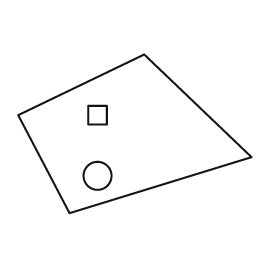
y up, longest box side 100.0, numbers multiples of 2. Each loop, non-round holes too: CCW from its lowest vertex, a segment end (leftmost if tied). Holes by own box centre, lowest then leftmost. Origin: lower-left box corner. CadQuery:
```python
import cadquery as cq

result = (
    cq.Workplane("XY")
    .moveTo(22.0, 0.0)
    .lineTo(100.0, 24.0)
    .lineTo(54.0, 68.0)
    .lineTo(0.0, 42.0)
    .close()
    .moveTo(34.0, 16.0)
    .circle(6.0)
    .moveTo(30.0, 38.0)
    .lineTo(38.0, 38.0)
    .lineTo(38.0, 46.0)
    .lineTo(30.0, 46.0)
    .close()
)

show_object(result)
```